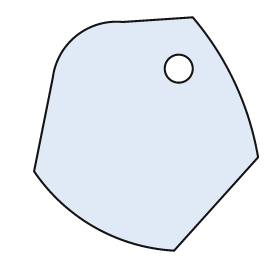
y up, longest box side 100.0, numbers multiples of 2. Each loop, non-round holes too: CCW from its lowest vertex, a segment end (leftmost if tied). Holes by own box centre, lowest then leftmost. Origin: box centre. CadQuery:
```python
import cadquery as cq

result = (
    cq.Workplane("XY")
    .moveTo(12.0, -50.0)
    .lineTo(48.0, -10.0)
    .threePointArc((38.0, 22.0), (20.0, 50.0))
    .lineTo(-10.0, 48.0)
    .threePointArc((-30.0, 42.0), (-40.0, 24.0))
    .lineTo(-48.0, -16.0)
    .threePointArc((-22.0, -40.0), (12.0, -50.0))
    .close()
    .moveTo(14.0, 28.0)
    .circle(6.0)
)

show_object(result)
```